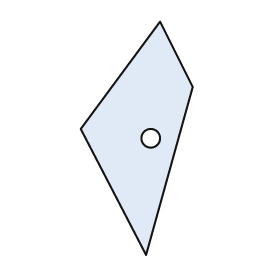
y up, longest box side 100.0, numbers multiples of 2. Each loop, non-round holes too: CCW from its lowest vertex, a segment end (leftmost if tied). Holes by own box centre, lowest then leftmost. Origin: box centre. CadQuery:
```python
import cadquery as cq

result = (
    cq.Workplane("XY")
    .moveTo(4.0, -50.0)
    .lineTo(24.0, 22.0)
    .lineTo(10.0, 50.0)
    .lineTo(-24.0, 4.0)
    .close()
    .moveTo(6.0, 0.0)
    .circle(4.0)
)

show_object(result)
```